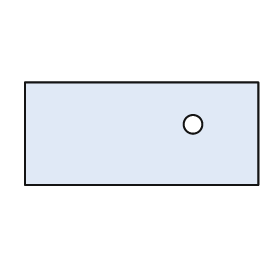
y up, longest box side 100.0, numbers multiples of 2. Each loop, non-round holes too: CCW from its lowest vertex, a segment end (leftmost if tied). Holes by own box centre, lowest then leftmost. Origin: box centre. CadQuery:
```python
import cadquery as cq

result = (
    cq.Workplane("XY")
    .moveTo(-50.0, -22.0)
    .lineTo(50.0, -22.0)
    .lineTo(50.0, 22.0)
    .lineTo(-50.0, 22.0)
    .close()
    .moveTo(22.0, 4.0)
    .circle(4.0)
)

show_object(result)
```